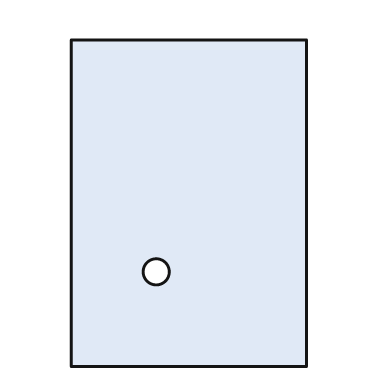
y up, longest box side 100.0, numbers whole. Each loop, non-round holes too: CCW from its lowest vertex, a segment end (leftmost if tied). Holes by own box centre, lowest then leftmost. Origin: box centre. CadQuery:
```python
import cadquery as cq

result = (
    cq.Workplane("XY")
    .moveTo(-36.0, -50.0)
    .lineTo(36.0, -50.0)
    .lineTo(36.0, 50.0)
    .lineTo(-36.0, 50.0)
    .close()
    .moveTo(-10.0, -21.0)
    .circle(4.0)
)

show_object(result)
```